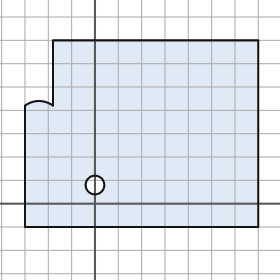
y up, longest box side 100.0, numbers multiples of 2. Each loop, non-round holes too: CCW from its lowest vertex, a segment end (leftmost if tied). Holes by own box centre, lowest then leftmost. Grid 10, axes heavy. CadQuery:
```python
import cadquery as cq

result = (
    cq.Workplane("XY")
    .moveTo(-30.0, -10.0)
    .lineTo(70.0, -10.0)
    .lineTo(70.0, 70.0)
    .lineTo(-18.0, 70.0)
    .lineTo(-18.0, 42.0)
    .threePointArc((-24.0, 44.0), (-30.0, 42.0))
    .close()
    .moveTo(0.0, 8.0)
    .circle(4.0)
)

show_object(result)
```